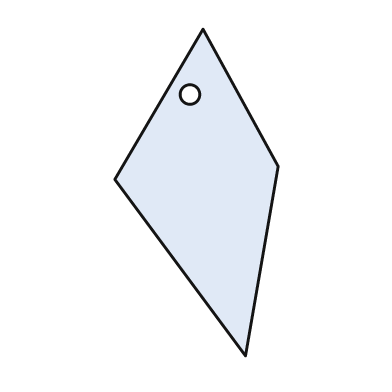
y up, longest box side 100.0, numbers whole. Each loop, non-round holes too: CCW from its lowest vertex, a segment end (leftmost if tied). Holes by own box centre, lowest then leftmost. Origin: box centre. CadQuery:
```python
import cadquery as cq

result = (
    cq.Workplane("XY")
    .moveTo(15.0, -50.0)
    .lineTo(25.0, 8.0)
    .lineTo(2.0, 50.0)
    .lineTo(-25.0, 4.0)
    .close()
    .moveTo(-2.0, 30.0)
    .circle(3.0)
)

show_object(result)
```